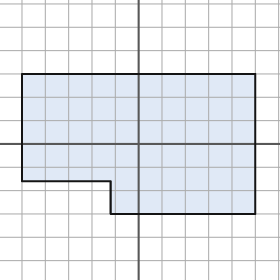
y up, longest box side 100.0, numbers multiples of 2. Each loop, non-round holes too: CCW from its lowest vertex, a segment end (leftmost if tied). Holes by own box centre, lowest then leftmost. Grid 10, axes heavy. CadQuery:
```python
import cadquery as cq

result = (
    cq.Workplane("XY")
    .moveTo(-12.0, -30.0)
    .lineTo(50.0, -30.0)
    .lineTo(50.0, 30.0)
    .lineTo(-50.0, 30.0)
    .lineTo(-50.0, -16.0)
    .lineTo(-12.0, -16.0)
    .close()
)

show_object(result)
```